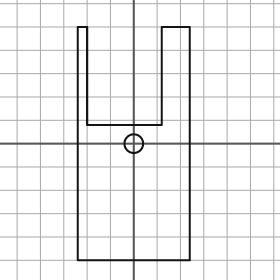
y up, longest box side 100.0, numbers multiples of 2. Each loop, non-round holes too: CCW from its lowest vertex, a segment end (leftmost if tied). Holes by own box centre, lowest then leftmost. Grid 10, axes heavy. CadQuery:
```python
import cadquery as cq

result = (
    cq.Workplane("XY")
    .moveTo(-24.0, -50.0)
    .lineTo(24.0, -50.0)
    .lineTo(24.0, 50.0)
    .lineTo(12.0, 50.0)
    .lineTo(12.0, 8.0)
    .lineTo(-20.0, 8.0)
    .lineTo(-20.0, 50.0)
    .lineTo(-24.0, 50.0)
    .close()
    .moveTo(0.0, 0.0)
    .circle(4.0)
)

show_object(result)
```